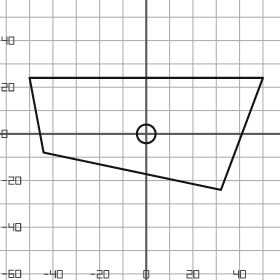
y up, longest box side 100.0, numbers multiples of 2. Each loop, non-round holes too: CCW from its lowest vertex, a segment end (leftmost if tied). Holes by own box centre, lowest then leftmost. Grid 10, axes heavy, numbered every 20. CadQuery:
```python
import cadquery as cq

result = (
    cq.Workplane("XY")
    .moveTo(32.0, -24.0)
    .lineTo(50.0, 24.0)
    .lineTo(-50.0, 24.0)
    .lineTo(-44.0, -8.0)
    .close()
    .moveTo(0.0, 0.0)
    .circle(4.0)
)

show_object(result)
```